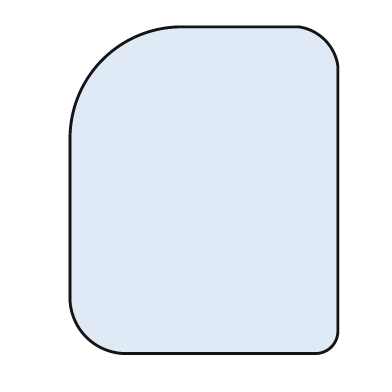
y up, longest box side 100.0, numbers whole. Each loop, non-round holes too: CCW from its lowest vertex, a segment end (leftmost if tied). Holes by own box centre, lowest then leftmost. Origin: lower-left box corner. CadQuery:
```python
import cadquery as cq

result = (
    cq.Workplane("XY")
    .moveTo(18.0, 0.0)
    .lineTo(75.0, 0.0)
    .threePointArc((80.0, 2.0), (82.0, 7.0))
    .lineTo(82.0, 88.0)
    .threePointArc((78.0, 96.0), (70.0, 100.0))
    .lineTo(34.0, 100.0)
    .threePointArc((10.0, 90.0), (0.0, 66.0))
    .lineTo(0.0, 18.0)
    .threePointArc((5.0, 5.0), (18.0, 0.0))
    .close()
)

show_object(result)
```